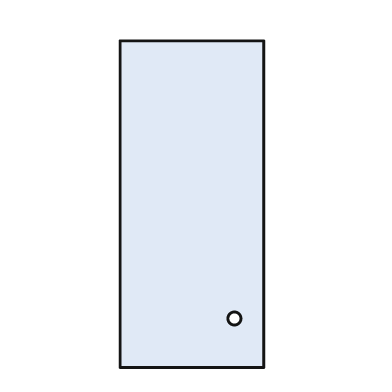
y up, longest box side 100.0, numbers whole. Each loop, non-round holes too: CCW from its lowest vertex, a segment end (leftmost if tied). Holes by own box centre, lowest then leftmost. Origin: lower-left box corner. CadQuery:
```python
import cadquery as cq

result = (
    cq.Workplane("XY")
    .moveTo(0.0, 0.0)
    .lineTo(44.0, 0.0)
    .lineTo(44.0, 100.0)
    .lineTo(0.0, 100.0)
    .close()
    .moveTo(35.0, 15.0)
    .circle(2.0)
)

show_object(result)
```